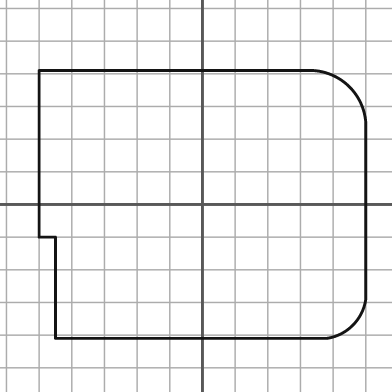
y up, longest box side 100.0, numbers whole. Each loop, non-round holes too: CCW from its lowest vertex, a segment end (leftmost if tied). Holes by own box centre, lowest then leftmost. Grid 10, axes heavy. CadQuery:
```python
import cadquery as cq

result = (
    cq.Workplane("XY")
    .moveTo(-45.0, -41.0)
    .lineTo(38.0, -41.0)
    .threePointArc((46.0, -37.0), (50.0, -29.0))
    .lineTo(50.0, 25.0)
    .threePointArc((45.0, 36.0), (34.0, 41.0))
    .lineTo(-50.0, 41.0)
    .lineTo(-50.0, -10.0)
    .lineTo(-45.0, -10.0)
    .close()
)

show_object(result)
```